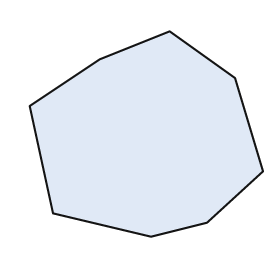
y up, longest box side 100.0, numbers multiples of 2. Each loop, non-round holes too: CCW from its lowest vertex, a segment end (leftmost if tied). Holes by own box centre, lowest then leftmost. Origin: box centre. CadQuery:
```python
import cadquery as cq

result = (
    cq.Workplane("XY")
    .moveTo(2.0, -44.0)
    .lineTo(26.0, -38.0)
    .lineTo(50.0, -16.0)
    .lineTo(38.0, 24.0)
    .lineTo(10.0, 44.0)
    .lineTo(-20.0, 32.0)
    .lineTo(-50.0, 12.0)
    .lineTo(-40.0, -34.0)
    .close()
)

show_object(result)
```